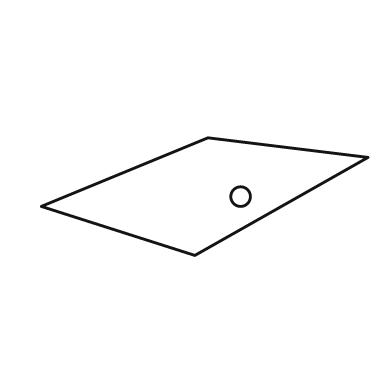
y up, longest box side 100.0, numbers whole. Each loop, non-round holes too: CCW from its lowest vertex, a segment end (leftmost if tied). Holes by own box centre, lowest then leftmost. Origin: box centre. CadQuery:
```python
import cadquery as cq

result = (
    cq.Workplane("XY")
    .moveTo(-3.0, -18.0)
    .lineTo(50.0, 12.0)
    .lineTo(1.0, 18.0)
    .lineTo(-50.0, -3.0)
    .close()
    .moveTo(11.0, 0.0)
    .circle(3.0)
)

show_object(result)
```